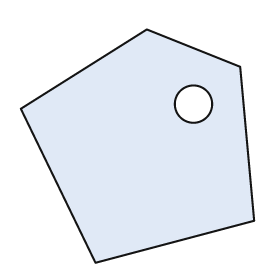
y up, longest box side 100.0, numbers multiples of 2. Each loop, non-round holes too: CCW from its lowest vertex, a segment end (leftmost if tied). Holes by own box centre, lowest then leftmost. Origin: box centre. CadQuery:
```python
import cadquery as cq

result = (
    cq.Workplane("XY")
    .moveTo(-18.0, -50.0)
    .lineTo(50.0, -32.0)
    .lineTo(44.0, 34.0)
    .lineTo(4.0, 50.0)
    .lineTo(-50.0, 16.0)
    .close()
    .moveTo(24.0, 18.0)
    .circle(8.0)
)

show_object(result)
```